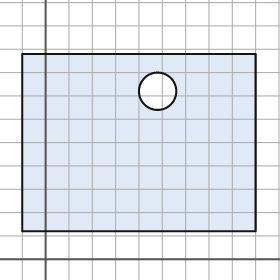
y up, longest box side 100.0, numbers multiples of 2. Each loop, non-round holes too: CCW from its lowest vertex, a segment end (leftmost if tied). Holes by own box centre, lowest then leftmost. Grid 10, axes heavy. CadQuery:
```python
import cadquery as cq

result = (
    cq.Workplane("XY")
    .moveTo(-10.0, 12.0)
    .lineTo(90.0, 12.0)
    .lineTo(90.0, 88.0)
    .lineTo(-10.0, 88.0)
    .close()
    .moveTo(48.0, 72.0)
    .circle(8.0)
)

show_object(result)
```